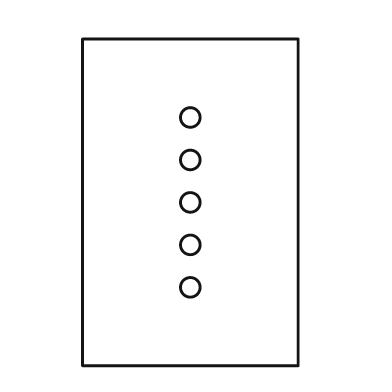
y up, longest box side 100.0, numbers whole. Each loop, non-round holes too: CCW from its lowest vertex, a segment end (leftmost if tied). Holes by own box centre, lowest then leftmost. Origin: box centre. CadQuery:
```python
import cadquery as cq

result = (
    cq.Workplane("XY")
    .moveTo(-33.0, -50.0)
    .lineTo(33.0, -50.0)
    .lineTo(33.0, 50.0)
    .lineTo(-33.0, 50.0)
    .close()
    .moveTo(0.0, -26.0)
    .circle(3.0)
    .moveTo(0.0, -13.0)
    .circle(3.0)
    .moveTo(0.0, 0.0)
    .circle(3.0)
    .moveTo(0.0, 13.0)
    .circle(3.0)
    .moveTo(0.0, 26.0)
    .circle(3.0)
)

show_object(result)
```